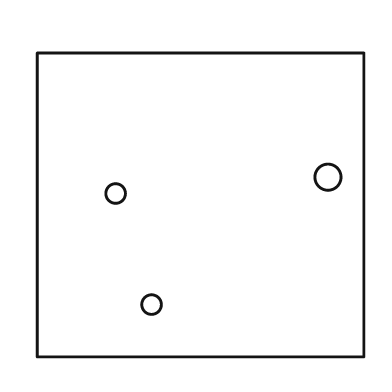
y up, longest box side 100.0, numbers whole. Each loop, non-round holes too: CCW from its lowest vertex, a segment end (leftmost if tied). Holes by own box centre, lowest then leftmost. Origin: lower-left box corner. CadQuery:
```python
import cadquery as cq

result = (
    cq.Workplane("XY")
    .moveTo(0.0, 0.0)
    .lineTo(100.0, 0.0)
    .lineTo(100.0, 93.0)
    .lineTo(0.0, 93.0)
    .close()
    .moveTo(35.0, 16.0)
    .circle(3.0)
    .moveTo(24.0, 50.0)
    .circle(3.0)
    .moveTo(89.0, 55.0)
    .circle(4.0)
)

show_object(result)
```